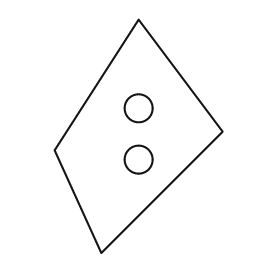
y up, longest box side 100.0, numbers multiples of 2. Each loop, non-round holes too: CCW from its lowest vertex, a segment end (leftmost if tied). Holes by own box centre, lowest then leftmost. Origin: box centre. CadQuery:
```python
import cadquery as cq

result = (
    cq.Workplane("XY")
    .moveTo(-16.0, -50.0)
    .lineTo(36.0, 2.0)
    .lineTo(0.0, 50.0)
    .lineTo(-36.0, -6.0)
    .close()
    .moveTo(0.0, -10.0)
    .circle(6.0)
    .moveTo(0.0, 12.0)
    .circle(6.0)
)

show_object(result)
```